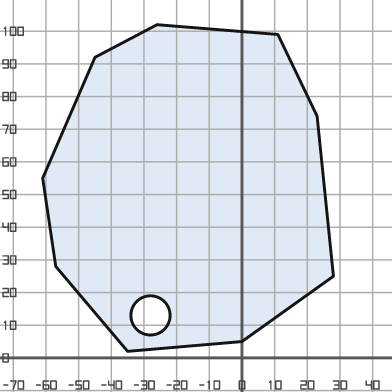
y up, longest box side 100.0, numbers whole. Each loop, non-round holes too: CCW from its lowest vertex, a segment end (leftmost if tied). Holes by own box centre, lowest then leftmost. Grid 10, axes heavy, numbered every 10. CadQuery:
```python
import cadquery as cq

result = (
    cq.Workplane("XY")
    .moveTo(-35.0, 2.0)
    .lineTo(0.0, 5.0)
    .lineTo(28.0, 25.0)
    .lineTo(23.0, 74.0)
    .lineTo(11.0, 99.0)
    .lineTo(-26.0, 102.0)
    .lineTo(-45.0, 92.0)
    .lineTo(-61.0, 55.0)
    .lineTo(-57.0, 28.0)
    .close()
    .moveTo(-28.0, 13.0)
    .circle(6.0)
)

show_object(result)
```